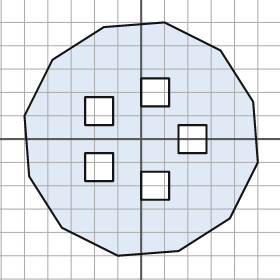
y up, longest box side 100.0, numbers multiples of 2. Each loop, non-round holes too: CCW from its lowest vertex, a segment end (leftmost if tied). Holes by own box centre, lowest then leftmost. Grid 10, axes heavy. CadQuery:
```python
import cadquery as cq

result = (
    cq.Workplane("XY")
    .moveTo(-10.0, -50.0)
    .lineTo(16.0, -48.0)
    .lineTo(38.0, -34.0)
    .lineTo(50.0, -10.0)
    .lineTo(48.0, 16.0)
    .lineTo(34.0, 38.0)
    .lineTo(10.0, 50.0)
    .lineTo(-16.0, 48.0)
    .lineTo(-38.0, 34.0)
    .lineTo(-50.0, 10.0)
    .lineTo(-48.0, -16.0)
    .lineTo(-34.0, -38.0)
    .close()
    .moveTo(0.0, -26.0)
    .lineTo(12.0, -26.0)
    .lineTo(12.0, -14.0)
    .lineTo(0.0, -14.0)
    .close()
    .moveTo(-24.0, -18.0)
    .lineTo(-12.0, -18.0)
    .lineTo(-12.0, -6.0)
    .lineTo(-24.0, -6.0)
    .close()
    .moveTo(16.0, -6.0)
    .lineTo(28.0, -6.0)
    .lineTo(28.0, 6.0)
    .lineTo(16.0, 6.0)
    .close()
    .moveTo(-24.0, 6.0)
    .lineTo(-12.0, 6.0)
    .lineTo(-12.0, 18.0)
    .lineTo(-24.0, 18.0)
    .close()
    .moveTo(0.0, 14.0)
    .lineTo(12.0, 14.0)
    .lineTo(12.0, 26.0)
    .lineTo(0.0, 26.0)
    .close()
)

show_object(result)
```